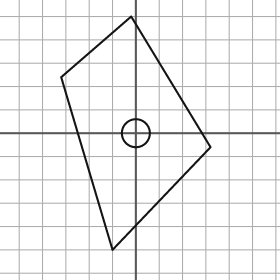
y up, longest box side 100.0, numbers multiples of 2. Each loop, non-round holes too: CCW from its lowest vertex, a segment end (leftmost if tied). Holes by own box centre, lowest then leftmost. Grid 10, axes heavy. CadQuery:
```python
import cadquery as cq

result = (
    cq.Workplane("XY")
    .moveTo(-10.0, -50.0)
    .lineTo(32.0, -6.0)
    .lineTo(-2.0, 50.0)
    .lineTo(-32.0, 24.0)
    .close()
    .moveTo(0.0, 0.0)
    .circle(6.0)
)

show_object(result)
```